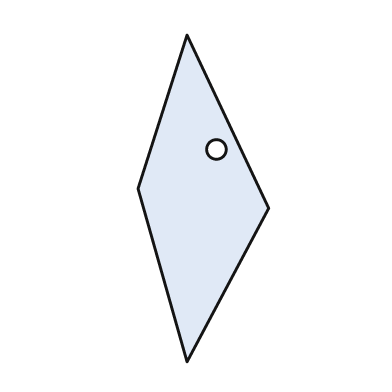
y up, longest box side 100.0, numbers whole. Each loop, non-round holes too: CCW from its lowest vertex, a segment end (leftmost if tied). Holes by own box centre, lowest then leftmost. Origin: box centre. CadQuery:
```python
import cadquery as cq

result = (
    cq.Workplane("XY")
    .moveTo(-5.0, -50.0)
    .lineTo(20.0, -3.0)
    .lineTo(-5.0, 50.0)
    .lineTo(-20.0, 3.0)
    .close()
    .moveTo(4.0, 15.0)
    .circle(3.0)
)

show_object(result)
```